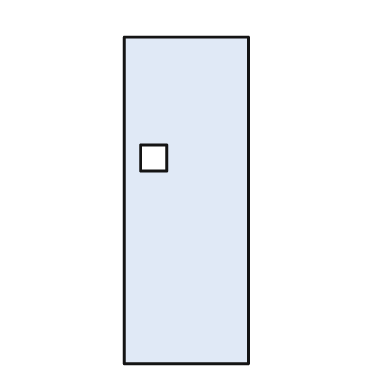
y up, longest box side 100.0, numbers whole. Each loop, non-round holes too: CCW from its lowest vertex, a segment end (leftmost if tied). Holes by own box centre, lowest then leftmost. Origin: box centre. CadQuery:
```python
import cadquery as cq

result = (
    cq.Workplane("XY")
    .moveTo(-19.0, -50.0)
    .lineTo(19.0, -50.0)
    .lineTo(19.0, 50.0)
    .lineTo(-19.0, 50.0)
    .close()
    .moveTo(-14.0, 9.0)
    .lineTo(-6.0, 9.0)
    .lineTo(-6.0, 17.0)
    .lineTo(-14.0, 17.0)
    .close()
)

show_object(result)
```